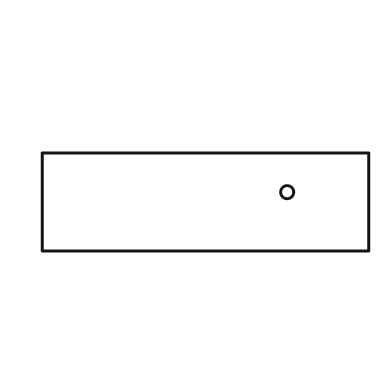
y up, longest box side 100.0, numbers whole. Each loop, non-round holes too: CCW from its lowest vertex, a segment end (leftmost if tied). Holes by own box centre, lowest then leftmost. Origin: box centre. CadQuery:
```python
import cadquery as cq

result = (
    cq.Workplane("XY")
    .moveTo(-50.0, -15.0)
    .lineTo(50.0, -15.0)
    .lineTo(50.0, 15.0)
    .lineTo(-50.0, 15.0)
    .close()
    .moveTo(25.0, 3.0)
    .circle(2.0)
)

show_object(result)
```